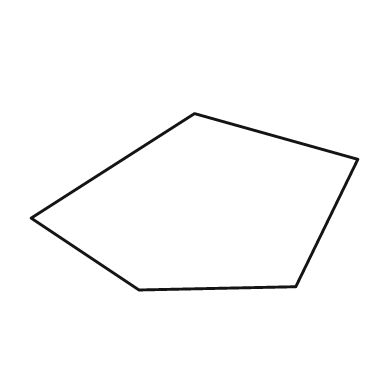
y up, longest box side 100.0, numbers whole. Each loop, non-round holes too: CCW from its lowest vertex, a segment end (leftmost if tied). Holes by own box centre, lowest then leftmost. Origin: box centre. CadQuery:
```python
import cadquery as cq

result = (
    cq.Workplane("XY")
    .moveTo(-17.0, -27.0)
    .lineTo(31.0, -26.0)
    .lineTo(50.0, 13.0)
    .lineTo(0.0, 27.0)
    .lineTo(-50.0, -5.0)
    .close()
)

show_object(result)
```